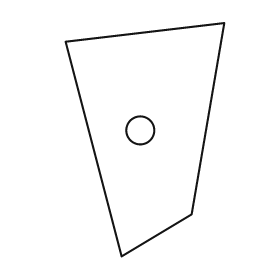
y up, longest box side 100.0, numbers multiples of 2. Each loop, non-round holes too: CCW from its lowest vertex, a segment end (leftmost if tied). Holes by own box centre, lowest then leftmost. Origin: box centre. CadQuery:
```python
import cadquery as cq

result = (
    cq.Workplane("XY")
    .moveTo(-10.0, -50.0)
    .lineTo(20.0, -32.0)
    .lineTo(34.0, 50.0)
    .lineTo(-34.0, 42.0)
    .close()
    .moveTo(-2.0, 4.0)
    .circle(6.0)
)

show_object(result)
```